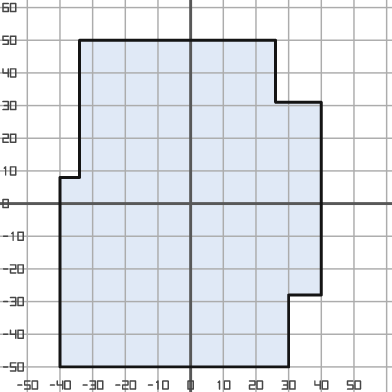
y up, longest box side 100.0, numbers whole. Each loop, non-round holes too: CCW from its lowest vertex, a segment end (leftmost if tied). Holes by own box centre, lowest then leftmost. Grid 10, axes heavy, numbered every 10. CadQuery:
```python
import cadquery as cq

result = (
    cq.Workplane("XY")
    .moveTo(-40.0, -50.0)
    .lineTo(30.0, -50.0)
    .lineTo(30.0, -28.0)
    .lineTo(40.0, -28.0)
    .lineTo(40.0, 31.0)
    .lineTo(26.0, 31.0)
    .lineTo(26.0, 50.0)
    .lineTo(-34.0, 50.0)
    .lineTo(-34.0, 8.0)
    .lineTo(-40.0, 8.0)
    .close()
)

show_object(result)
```